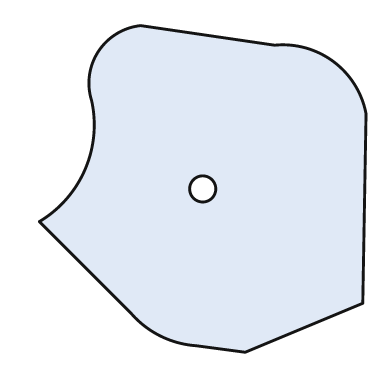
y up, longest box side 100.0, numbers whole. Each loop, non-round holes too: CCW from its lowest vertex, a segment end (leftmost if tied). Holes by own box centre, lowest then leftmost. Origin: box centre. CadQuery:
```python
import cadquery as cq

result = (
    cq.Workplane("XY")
    .moveTo(13.0, -50.0)
    .lineTo(49.0, -35.0)
    .lineTo(50.0, 23.0)
    .threePointArc((40.0, 39.0), (22.0, 44.0))
    .lineTo(-19.0, 50.0)
    .threePointArc((-32.0, 42.0), (-34.0, 27.0))
    .threePointArc((-36.0, 6.0), (-50.0, -10.0))
    .lineTo(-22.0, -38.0)
    .threePointArc((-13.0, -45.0), (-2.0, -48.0))
    .close()
    .moveTo(0.0, 0.0)
    .circle(4.0)
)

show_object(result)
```